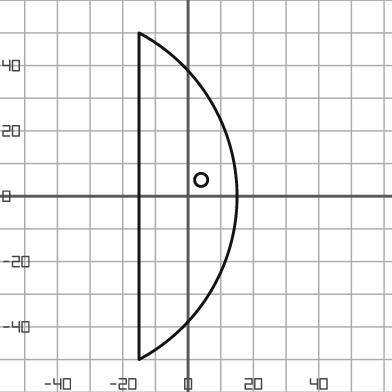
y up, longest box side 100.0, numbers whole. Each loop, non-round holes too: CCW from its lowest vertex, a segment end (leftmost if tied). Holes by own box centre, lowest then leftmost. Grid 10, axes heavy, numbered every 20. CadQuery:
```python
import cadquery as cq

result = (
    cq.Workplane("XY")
    .moveTo(-15.0, -50.0)
    .threePointArc((15.0, 0.0), (-15.0, 50.0))
    .close()
    .moveTo(4.0, 5.0)
    .circle(2.0)
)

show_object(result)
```